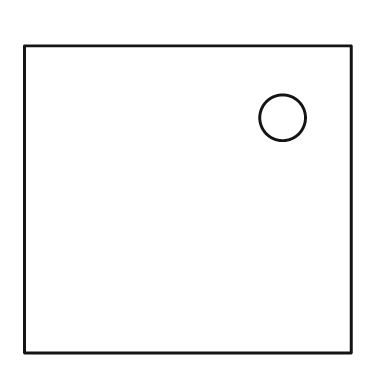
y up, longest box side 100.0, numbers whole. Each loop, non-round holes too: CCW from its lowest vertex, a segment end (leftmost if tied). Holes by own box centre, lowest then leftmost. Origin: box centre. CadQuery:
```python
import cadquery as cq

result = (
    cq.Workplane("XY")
    .moveTo(-50.0, -47.0)
    .lineTo(50.0, -47.0)
    .lineTo(50.0, 47.0)
    .lineTo(-50.0, 47.0)
    .close()
    .moveTo(29.0, 25.0)
    .circle(7.0)
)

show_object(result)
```